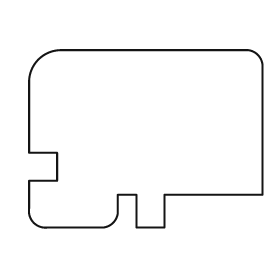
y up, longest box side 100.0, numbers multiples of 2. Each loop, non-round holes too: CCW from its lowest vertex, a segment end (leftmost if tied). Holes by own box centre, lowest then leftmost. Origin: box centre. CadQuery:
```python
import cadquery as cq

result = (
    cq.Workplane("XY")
    .moveTo(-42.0, -38.0)
    .lineTo(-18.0, -38.0)
    .threePointArc((-14.0, -36.0), (-12.0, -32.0))
    .lineTo(-12.0, -24.0)
    .lineTo(-4.0, -24.0)
    .lineTo(-4.0, -38.0)
    .lineTo(8.0, -38.0)
    .lineTo(8.0, -24.0)
    .lineTo(50.0, -24.0)
    .lineTo(50.0, 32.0)
    .threePointArc((48.0, 36.0), (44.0, 38.0))
    .lineTo(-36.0, 38.0)
    .threePointArc((-46.0, 34.0), (-50.0, 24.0))
    .lineTo(-50.0, -6.0)
    .lineTo(-38.0, -6.0)
    .lineTo(-38.0, -18.0)
    .lineTo(-50.0, -18.0)
    .lineTo(-50.0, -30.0)
    .threePointArc((-48.0, -36.0), (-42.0, -38.0))
    .close()
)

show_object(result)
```